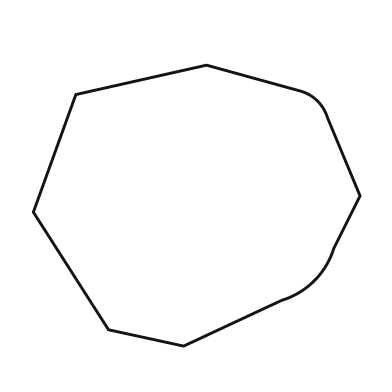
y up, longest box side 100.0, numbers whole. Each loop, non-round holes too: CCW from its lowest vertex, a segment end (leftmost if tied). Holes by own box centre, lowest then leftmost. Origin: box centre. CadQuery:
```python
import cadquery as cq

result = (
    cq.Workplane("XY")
    .moveTo(-4.0, -43.0)
    .lineTo(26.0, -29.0)
    .threePointArc((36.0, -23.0), (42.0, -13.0))
    .lineTo(50.0, 3.0)
    .lineTo(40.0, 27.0)
    .threePointArc((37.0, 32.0), (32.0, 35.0))
    .lineTo(3.0, 43.0)
    .lineTo(-37.0, 34.0)
    .lineTo(-50.0, -2.0)
    .lineTo(-27.0, -38.0)
    .close()
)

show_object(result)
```